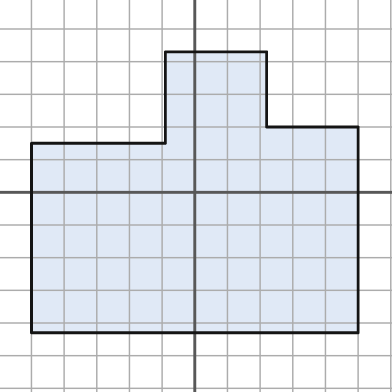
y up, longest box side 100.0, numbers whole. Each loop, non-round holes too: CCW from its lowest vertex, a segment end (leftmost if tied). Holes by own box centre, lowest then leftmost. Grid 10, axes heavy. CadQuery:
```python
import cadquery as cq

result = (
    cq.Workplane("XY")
    .moveTo(-50.0, -43.0)
    .lineTo(50.0, -43.0)
    .lineTo(50.0, 20.0)
    .lineTo(22.0, 20.0)
    .lineTo(22.0, 43.0)
    .lineTo(-9.0, 43.0)
    .lineTo(-9.0, 15.0)
    .lineTo(-50.0, 15.0)
    .close()
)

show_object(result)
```